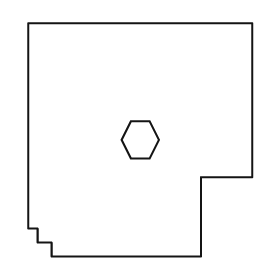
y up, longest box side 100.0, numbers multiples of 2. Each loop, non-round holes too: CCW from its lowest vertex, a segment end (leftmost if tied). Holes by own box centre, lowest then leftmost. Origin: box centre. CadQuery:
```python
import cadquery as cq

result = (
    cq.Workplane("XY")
    .moveTo(-38.0, -50.0)
    .lineTo(26.0, -50.0)
    .lineTo(26.0, -16.0)
    .lineTo(48.0, -16.0)
    .lineTo(48.0, 50.0)
    .lineTo(-48.0, 50.0)
    .lineTo(-48.0, -38.0)
    .lineTo(-44.0, -38.0)
    .lineTo(-44.0, -44.0)
    .lineTo(-38.0, -44.0)
    .close()
    .moveTo(-4.0, -8.0)
    .lineTo(4.0, -8.0)
    .lineTo(8.0, 0.0)
    .lineTo(4.0, 8.0)
    .lineTo(-4.0, 8.0)
    .lineTo(-8.0, 0.0)
    .close()
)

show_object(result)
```